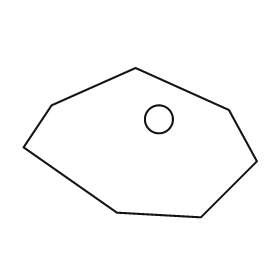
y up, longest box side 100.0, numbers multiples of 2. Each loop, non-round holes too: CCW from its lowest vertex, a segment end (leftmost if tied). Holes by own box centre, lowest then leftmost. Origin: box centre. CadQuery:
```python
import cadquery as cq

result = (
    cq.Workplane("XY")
    .moveTo(26.0, -32.0)
    .lineTo(50.0, -8.0)
    .lineTo(38.0, 14.0)
    .lineTo(-2.0, 32.0)
    .lineTo(-38.0, 16.0)
    .lineTo(-50.0, -2.0)
    .lineTo(-10.0, -30.0)
    .close()
    .moveTo(8.0, 10.0)
    .circle(6.0)
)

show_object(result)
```